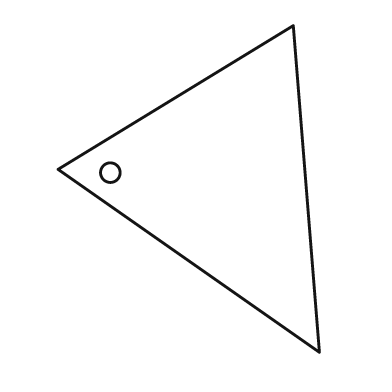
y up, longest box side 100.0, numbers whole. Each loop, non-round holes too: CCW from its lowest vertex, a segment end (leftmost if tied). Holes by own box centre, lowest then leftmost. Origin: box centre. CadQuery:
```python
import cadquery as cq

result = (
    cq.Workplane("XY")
    .moveTo(40.0, -50.0)
    .lineTo(32.0, 50.0)
    .lineTo(-40.0, 6.0)
    .close()
    .moveTo(-24.0, 5.0)
    .circle(3.0)
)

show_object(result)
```